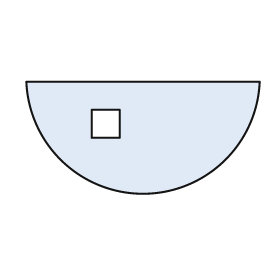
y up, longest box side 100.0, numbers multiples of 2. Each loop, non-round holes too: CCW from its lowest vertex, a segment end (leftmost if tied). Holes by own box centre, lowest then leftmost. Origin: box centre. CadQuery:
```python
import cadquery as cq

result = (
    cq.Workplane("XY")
    .moveTo(-50.0, 24.0)
    .threePointArc((0.0, -24.0), (50.0, 24.0))
    .close()
    .moveTo(-22.0, 0.0)
    .lineTo(-10.0, 0.0)
    .lineTo(-10.0, 12.0)
    .lineTo(-22.0, 12.0)
    .close()
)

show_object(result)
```